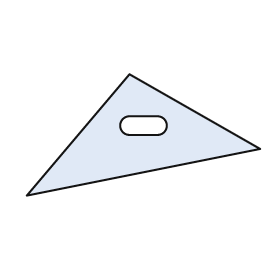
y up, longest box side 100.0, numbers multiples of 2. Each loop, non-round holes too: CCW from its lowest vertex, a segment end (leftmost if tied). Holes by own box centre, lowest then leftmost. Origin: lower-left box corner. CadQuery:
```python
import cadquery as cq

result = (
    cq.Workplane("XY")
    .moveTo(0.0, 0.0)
    .lineTo(100.0, 20.0)
    .lineTo(44.0, 52.0)
    .close()
    .moveTo(44.0, 26.0)
    .lineTo(56.0, 26.0)
    .threePointArc((60.0, 30.0), (56.0, 34.0))
    .lineTo(44.0, 34.0)
    .threePointArc((40.0, 30.0), (44.0, 26.0))
    .close()
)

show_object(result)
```